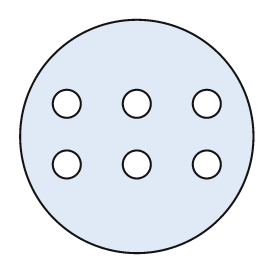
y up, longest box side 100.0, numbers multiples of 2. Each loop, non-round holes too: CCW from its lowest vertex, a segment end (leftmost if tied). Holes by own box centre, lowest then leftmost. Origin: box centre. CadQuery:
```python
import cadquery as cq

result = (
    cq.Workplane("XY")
    .moveTo(0.0, 0.0)
    .circle(50.0)
    .moveTo(-30.0, -12.0)
    .circle(6.0)
    .moveTo(0.0, -12.0)
    .circle(6.0)
    .moveTo(30.0, -12.0)
    .circle(6.0)
    .moveTo(-30.0, 14.0)
    .circle(6.0)
    .moveTo(0.0, 14.0)
    .circle(6.0)
    .moveTo(30.0, 14.0)
    .circle(6.0)
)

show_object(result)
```